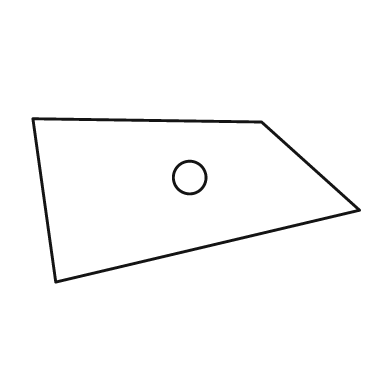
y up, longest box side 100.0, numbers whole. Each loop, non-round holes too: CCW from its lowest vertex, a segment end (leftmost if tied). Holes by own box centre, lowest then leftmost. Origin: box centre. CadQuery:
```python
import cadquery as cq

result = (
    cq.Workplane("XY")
    .moveTo(-43.0, -25.0)
    .lineTo(50.0, -3.0)
    .lineTo(20.0, 24.0)
    .lineTo(-50.0, 25.0)
    .close()
    .moveTo(-2.0, 7.0)
    .circle(5.0)
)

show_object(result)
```